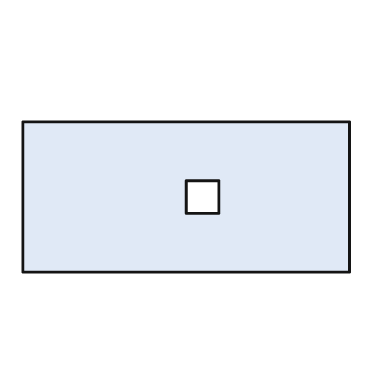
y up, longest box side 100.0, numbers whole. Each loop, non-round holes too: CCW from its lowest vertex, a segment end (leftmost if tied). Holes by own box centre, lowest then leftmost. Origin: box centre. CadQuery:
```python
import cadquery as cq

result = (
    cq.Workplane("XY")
    .moveTo(-50.0, -23.0)
    .lineTo(50.0, -23.0)
    .lineTo(50.0, 23.0)
    .lineTo(-50.0, 23.0)
    .close()
    .moveTo(0.0, -5.0)
    .lineTo(10.0, -5.0)
    .lineTo(10.0, 5.0)
    .lineTo(0.0, 5.0)
    .close()
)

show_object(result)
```